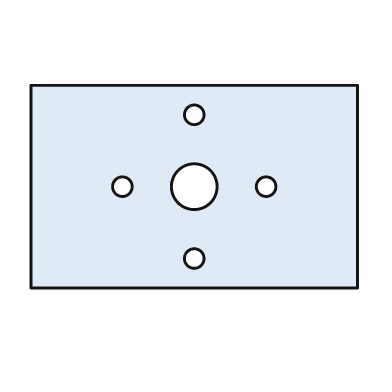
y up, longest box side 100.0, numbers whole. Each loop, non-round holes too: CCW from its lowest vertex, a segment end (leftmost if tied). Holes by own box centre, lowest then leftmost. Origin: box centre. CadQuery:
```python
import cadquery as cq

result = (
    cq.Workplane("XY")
    .moveTo(-50.0, -31.0)
    .lineTo(50.0, -31.0)
    .lineTo(50.0, 31.0)
    .lineTo(-50.0, 31.0)
    .close()
    .moveTo(0.0, -22.0)
    .circle(3.0)
    .moveTo(-22.0, 0.0)
    .circle(3.0)
    .moveTo(0.0, 0.0)
    .circle(7.0)
    .moveTo(22.0, 0.0)
    .circle(3.0)
    .moveTo(0.0, 22.0)
    .circle(3.0)
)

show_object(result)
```